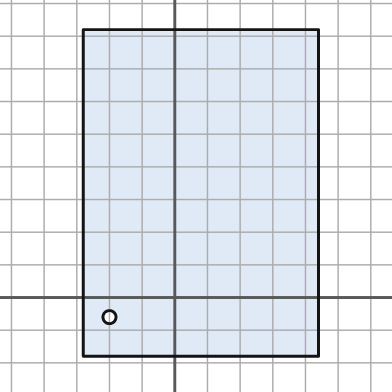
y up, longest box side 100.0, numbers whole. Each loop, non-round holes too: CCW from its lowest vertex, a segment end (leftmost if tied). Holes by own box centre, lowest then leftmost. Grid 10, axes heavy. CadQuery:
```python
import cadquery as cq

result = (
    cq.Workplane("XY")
    .moveTo(-28.0, -18.0)
    .lineTo(44.0, -18.0)
    .lineTo(44.0, 82.0)
    .lineTo(-28.0, 82.0)
    .close()
    .moveTo(-20.0, -6.0)
    .circle(2.0)
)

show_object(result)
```